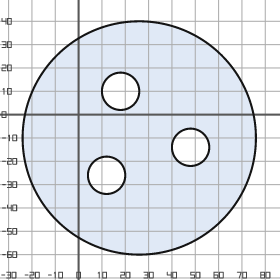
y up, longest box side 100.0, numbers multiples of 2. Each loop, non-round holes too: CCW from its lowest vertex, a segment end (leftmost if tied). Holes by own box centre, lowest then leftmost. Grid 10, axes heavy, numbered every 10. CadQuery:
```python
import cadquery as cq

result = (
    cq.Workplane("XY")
    .moveTo(26.0, -10.0)
    .circle(50.0)
    .moveTo(12.0, -26.0)
    .circle(8.0)
    .moveTo(48.0, -14.0)
    .circle(8.0)
    .moveTo(18.0, 10.0)
    .circle(8.0)
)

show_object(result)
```